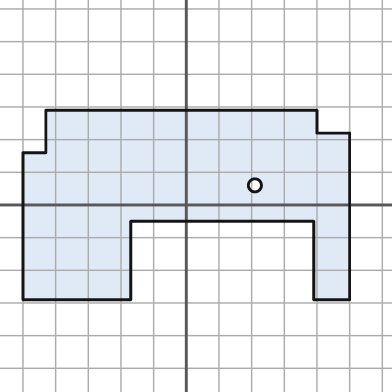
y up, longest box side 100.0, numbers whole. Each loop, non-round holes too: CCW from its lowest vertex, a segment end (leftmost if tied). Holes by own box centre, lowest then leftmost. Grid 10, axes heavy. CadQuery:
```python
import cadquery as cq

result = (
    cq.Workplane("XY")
    .moveTo(-50.0, -29.0)
    .lineTo(-17.0, -29.0)
    .lineTo(-17.0, -5.0)
    .lineTo(39.0, -5.0)
    .lineTo(39.0, -29.0)
    .lineTo(50.0, -29.0)
    .lineTo(50.0, 22.0)
    .lineTo(40.0, 22.0)
    .lineTo(40.0, 29.0)
    .lineTo(-43.0, 29.0)
    .lineTo(-43.0, 16.0)
    .lineTo(-50.0, 16.0)
    .close()
    .moveTo(21.0, 6.0)
    .circle(2.0)
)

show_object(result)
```